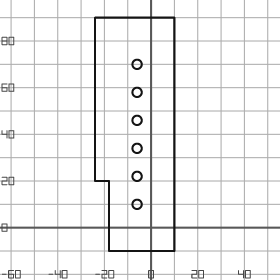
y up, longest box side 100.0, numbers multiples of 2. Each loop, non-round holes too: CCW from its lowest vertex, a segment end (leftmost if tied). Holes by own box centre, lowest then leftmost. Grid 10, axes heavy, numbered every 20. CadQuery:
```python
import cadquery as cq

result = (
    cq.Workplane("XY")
    .moveTo(-18.0, -10.0)
    .lineTo(10.0, -10.0)
    .lineTo(10.0, 90.0)
    .lineTo(-24.0, 90.0)
    .lineTo(-24.0, 20.0)
    .lineTo(-18.0, 20.0)
    .close()
    .moveTo(-6.0, 10.0)
    .circle(2.0)
    .moveTo(-6.0, 22.0)
    .circle(2.0)
    .moveTo(-6.0, 34.0)
    .circle(2.0)
    .moveTo(-6.0, 46.0)
    .circle(2.0)
    .moveTo(-6.0, 58.0)
    .circle(2.0)
    .moveTo(-6.0, 70.0)
    .circle(2.0)
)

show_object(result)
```